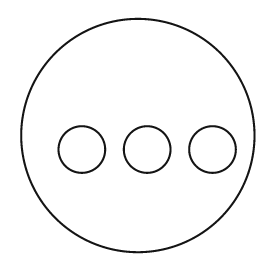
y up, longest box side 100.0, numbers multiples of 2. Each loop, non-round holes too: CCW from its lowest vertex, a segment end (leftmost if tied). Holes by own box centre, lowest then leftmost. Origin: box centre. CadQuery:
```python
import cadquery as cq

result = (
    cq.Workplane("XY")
    .moveTo(0.0, 0.0)
    .circle(50.0)
    .moveTo(-24.0, -6.0)
    .circle(10.0)
    .moveTo(4.0, -6.0)
    .circle(10.0)
    .moveTo(32.0, -6.0)
    .circle(10.0)
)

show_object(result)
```